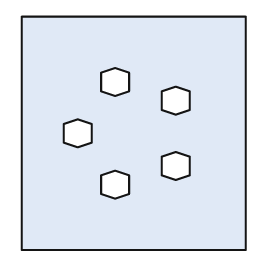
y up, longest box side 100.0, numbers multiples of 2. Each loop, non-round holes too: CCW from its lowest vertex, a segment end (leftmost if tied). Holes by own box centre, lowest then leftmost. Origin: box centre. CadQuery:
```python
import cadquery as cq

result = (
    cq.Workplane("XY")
    .moveTo(-48.0, -50.0)
    .lineTo(48.0, -50.0)
    .lineTo(48.0, 50.0)
    .lineTo(-48.0, 50.0)
    .close()
    .moveTo(-8.0, -28.0)
    .lineTo(-2.0, -26.0)
    .lineTo(-2.0, -18.0)
    .lineTo(-8.0, -16.0)
    .lineTo(-14.0, -18.0)
    .lineTo(-14.0, -26.0)
    .close()
    .moveTo(18.0, -20.0)
    .lineTo(24.0, -18.0)
    .lineTo(24.0, -10.0)
    .lineTo(18.0, -8.0)
    .lineTo(12.0, -10.0)
    .lineTo(12.0, -18.0)
    .close()
    .moveTo(-24.0, -6.0)
    .lineTo(-18.0, -4.0)
    .lineTo(-18.0, 4.0)
    .lineTo(-24.0, 6.0)
    .lineTo(-30.0, 4.0)
    .lineTo(-30.0, -4.0)
    .close()
    .moveTo(18.0, 8.0)
    .lineTo(24.0, 10.0)
    .lineTo(24.0, 18.0)
    .lineTo(18.0, 20.0)
    .lineTo(12.0, 18.0)
    .lineTo(12.0, 10.0)
    .close()
    .moveTo(-8.0, 16.0)
    .lineTo(-2.0, 18.0)
    .lineTo(-2.0, 26.0)
    .lineTo(-8.0, 28.0)
    .lineTo(-14.0, 26.0)
    .lineTo(-14.0, 18.0)
    .close()
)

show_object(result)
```